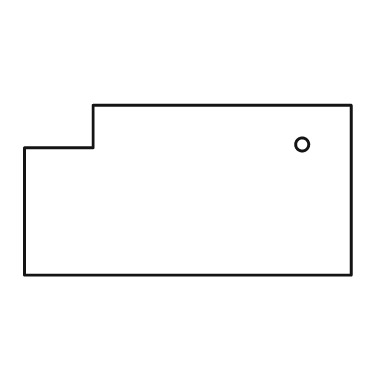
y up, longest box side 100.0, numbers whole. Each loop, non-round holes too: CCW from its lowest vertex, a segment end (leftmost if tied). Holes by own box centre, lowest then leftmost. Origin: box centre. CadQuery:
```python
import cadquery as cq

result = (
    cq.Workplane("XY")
    .moveTo(-50.0, -26.0)
    .lineTo(50.0, -26.0)
    .lineTo(50.0, 26.0)
    .lineTo(-29.0, 26.0)
    .lineTo(-29.0, 13.0)
    .lineTo(-50.0, 13.0)
    .close()
    .moveTo(35.0, 14.0)
    .circle(2.0)
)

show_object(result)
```